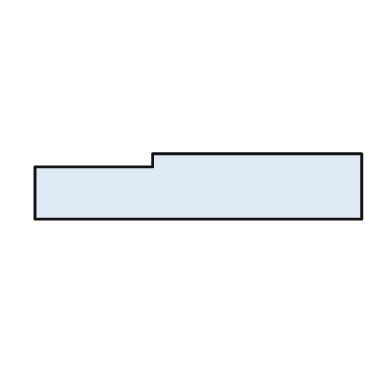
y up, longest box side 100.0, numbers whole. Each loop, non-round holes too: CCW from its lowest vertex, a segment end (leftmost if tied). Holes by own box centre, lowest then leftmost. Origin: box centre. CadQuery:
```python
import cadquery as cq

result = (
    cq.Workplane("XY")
    .moveTo(-50.0, -10.0)
    .lineTo(50.0, -10.0)
    .lineTo(50.0, 10.0)
    .lineTo(-14.0, 10.0)
    .lineTo(-14.0, 6.0)
    .lineTo(-50.0, 6.0)
    .close()
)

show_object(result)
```